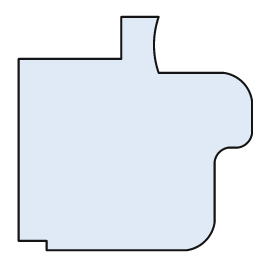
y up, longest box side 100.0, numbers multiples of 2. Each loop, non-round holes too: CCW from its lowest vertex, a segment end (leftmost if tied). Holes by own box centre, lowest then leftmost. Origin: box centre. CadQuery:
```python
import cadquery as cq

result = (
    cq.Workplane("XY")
    .moveTo(-38.0, -50.0)
    .lineTo(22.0, -50.0)
    .threePointArc((30.0, -46.0), (34.0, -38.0))
    .lineTo(34.0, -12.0)
    .threePointArc((36.0, -8.0), (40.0, -6.0))
    .lineTo(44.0, -6.0)
    .threePointArc((48.0, -4.0), (50.0, 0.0))
    .lineTo(50.0, 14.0)
    .threePointArc((46.0, 22.0), (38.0, 26.0))
    .lineTo(10.0, 26.0)
    .threePointArc((8.0, 38.0), (10.0, 50.0))
    .lineTo(-6.0, 50.0)
    .lineTo(-6.0, 32.0)
    .lineTo(-50.0, 32.0)
    .lineTo(-50.0, -46.0)
    .lineTo(-38.0, -46.0)
    .close()
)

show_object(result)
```